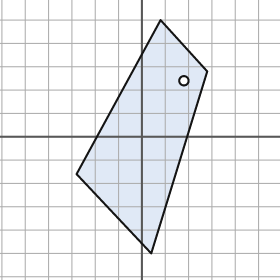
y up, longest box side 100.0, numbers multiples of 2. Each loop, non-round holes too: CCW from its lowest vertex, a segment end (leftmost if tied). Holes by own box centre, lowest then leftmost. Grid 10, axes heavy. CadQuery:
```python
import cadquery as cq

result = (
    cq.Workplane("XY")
    .moveTo(4.0, -50.0)
    .lineTo(28.0, 28.0)
    .lineTo(8.0, 50.0)
    .lineTo(-28.0, -16.0)
    .close()
    .moveTo(18.0, 24.0)
    .circle(2.0)
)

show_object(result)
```